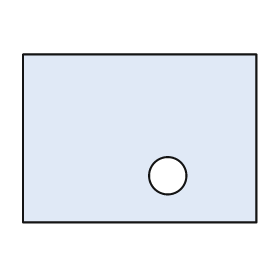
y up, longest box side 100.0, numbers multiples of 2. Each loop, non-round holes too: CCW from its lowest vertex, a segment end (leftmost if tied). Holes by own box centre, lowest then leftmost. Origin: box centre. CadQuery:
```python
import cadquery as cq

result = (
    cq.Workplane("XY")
    .moveTo(-50.0, -36.0)
    .lineTo(50.0, -36.0)
    .lineTo(50.0, 36.0)
    .lineTo(-50.0, 36.0)
    .close()
    .moveTo(12.0, -16.0)
    .circle(8.0)
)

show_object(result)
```